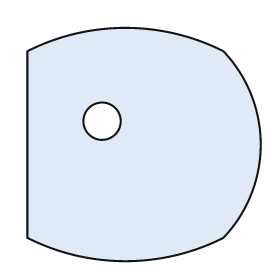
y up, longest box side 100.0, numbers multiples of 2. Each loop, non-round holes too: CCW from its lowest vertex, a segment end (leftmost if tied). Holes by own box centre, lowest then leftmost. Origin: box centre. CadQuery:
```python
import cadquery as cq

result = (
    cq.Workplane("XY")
    .moveTo(-50.0, -40.0)
    .threePointArc((-8.0, -50.0), (34.0, -40.0))
    .threePointArc((50.0, 0.0), (34.0, 40.0))
    .threePointArc((-8.0, 50.0), (-50.0, 40.0))
    .close()
    .moveTo(-18.0, 10.0)
    .circle(8.0)
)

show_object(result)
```